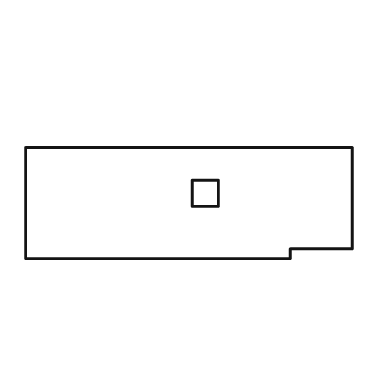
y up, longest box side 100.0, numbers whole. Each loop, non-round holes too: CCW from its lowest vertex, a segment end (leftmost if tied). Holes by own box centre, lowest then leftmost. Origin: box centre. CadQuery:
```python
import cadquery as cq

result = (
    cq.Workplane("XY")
    .moveTo(-50.0, -17.0)
    .lineTo(31.0, -17.0)
    .lineTo(31.0, -14.0)
    .lineTo(50.0, -14.0)
    .lineTo(50.0, 17.0)
    .lineTo(-50.0, 17.0)
    .close()
    .moveTo(1.0, -1.0)
    .lineTo(9.0, -1.0)
    .lineTo(9.0, 7.0)
    .lineTo(1.0, 7.0)
    .close()
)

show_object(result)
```